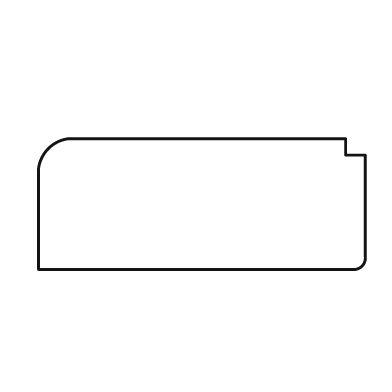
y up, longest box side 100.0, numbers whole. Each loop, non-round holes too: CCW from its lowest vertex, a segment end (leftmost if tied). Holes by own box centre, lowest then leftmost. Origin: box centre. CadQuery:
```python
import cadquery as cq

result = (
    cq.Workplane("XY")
    .moveTo(-50.0, -20.0)
    .lineTo(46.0, -20.0)
    .threePointArc((49.0, -19.0), (50.0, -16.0))
    .lineTo(50.0, 15.0)
    .lineTo(44.0, 15.0)
    .lineTo(44.0, 20.0)
    .lineTo(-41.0, 20.0)
    .threePointArc((-47.0, 17.0), (-50.0, 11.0))
    .close()
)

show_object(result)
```